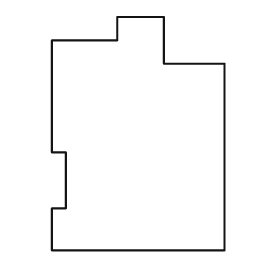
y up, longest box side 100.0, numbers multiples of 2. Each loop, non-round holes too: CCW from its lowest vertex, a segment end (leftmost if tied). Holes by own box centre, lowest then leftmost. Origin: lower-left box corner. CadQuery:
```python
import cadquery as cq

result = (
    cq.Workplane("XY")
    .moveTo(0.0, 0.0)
    .lineTo(74.0, 0.0)
    .lineTo(74.0, 80.0)
    .lineTo(48.0, 80.0)
    .lineTo(48.0, 100.0)
    .lineTo(28.0, 100.0)
    .lineTo(28.0, 90.0)
    .lineTo(0.0, 90.0)
    .lineTo(0.0, 42.0)
    .lineTo(6.0, 42.0)
    .lineTo(6.0, 18.0)
    .lineTo(0.0, 18.0)
    .close()
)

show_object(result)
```